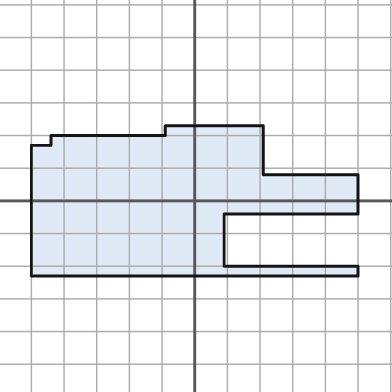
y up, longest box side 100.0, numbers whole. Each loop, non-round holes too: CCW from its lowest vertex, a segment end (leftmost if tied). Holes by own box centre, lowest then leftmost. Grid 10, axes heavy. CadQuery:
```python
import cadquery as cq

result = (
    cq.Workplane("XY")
    .moveTo(-50.0, -23.0)
    .lineTo(50.0, -23.0)
    .lineTo(50.0, -20.0)
    .lineTo(9.0, -20.0)
    .lineTo(9.0, -4.0)
    .lineTo(50.0, -4.0)
    .lineTo(50.0, 8.0)
    .lineTo(21.0, 8.0)
    .lineTo(21.0, 23.0)
    .lineTo(-9.0, 23.0)
    .lineTo(-9.0, 20.0)
    .lineTo(-44.0, 20.0)
    .lineTo(-44.0, 17.0)
    .lineTo(-50.0, 17.0)
    .close()
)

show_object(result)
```